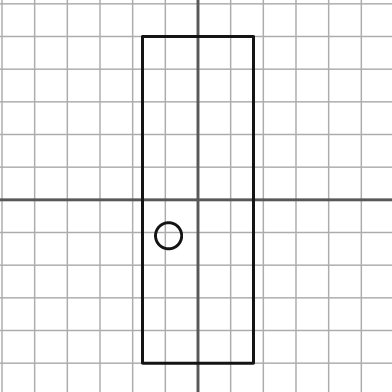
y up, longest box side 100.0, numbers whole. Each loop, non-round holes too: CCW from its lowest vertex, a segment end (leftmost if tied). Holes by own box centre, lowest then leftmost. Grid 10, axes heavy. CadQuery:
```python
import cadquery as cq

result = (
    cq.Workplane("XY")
    .moveTo(-17.0, -50.0)
    .lineTo(17.0, -50.0)
    .lineTo(17.0, 50.0)
    .lineTo(-17.0, 50.0)
    .close()
    .moveTo(-9.0, -11.0)
    .circle(4.0)
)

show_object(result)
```